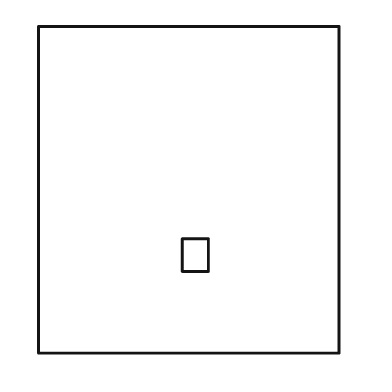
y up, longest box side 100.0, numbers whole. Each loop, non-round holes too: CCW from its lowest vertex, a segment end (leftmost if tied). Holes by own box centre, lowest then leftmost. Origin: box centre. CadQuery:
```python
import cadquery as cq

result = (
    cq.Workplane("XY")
    .moveTo(-46.0, -50.0)
    .lineTo(46.0, -50.0)
    .lineTo(46.0, 50.0)
    .lineTo(-46.0, 50.0)
    .close()
    .moveTo(-2.0, -25.0)
    .lineTo(6.0, -25.0)
    .lineTo(6.0, -15.0)
    .lineTo(-2.0, -15.0)
    .close()
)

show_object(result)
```